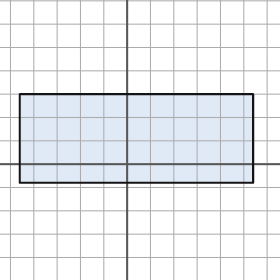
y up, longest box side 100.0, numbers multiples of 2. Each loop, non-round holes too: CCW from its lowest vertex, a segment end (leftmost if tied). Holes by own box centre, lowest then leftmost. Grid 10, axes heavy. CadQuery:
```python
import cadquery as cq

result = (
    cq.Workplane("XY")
    .moveTo(-46.0, -8.0)
    .lineTo(54.0, -8.0)
    .lineTo(54.0, 30.0)
    .lineTo(-46.0, 30.0)
    .close()
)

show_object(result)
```